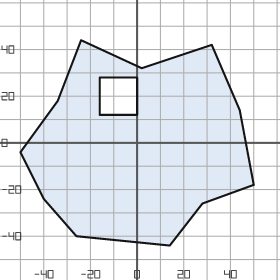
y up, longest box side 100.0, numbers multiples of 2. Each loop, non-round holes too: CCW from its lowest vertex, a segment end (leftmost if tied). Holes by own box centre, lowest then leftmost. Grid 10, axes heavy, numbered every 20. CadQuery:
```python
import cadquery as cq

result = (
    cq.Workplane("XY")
    .moveTo(14.0, -44.0)
    .lineTo(28.0, -26.0)
    .lineTo(50.0, -18.0)
    .lineTo(44.0, 14.0)
    .lineTo(32.0, 42.0)
    .lineTo(2.0, 32.0)
    .lineTo(-24.0, 44.0)
    .lineTo(-34.0, 18.0)
    .lineTo(-50.0, -4.0)
    .lineTo(-40.0, -24.0)
    .lineTo(-26.0, -40.0)
    .close()
    .moveTo(-16.0, 12.0)
    .lineTo(0.0, 12.0)
    .lineTo(0.0, 28.0)
    .lineTo(-16.0, 28.0)
    .close()
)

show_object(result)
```